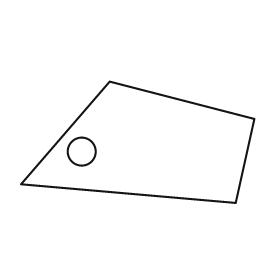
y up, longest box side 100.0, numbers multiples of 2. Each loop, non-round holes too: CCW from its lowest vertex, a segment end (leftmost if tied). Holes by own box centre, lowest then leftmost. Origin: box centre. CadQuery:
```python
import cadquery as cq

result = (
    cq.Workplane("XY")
    .moveTo(42.0, -26.0)
    .lineTo(50.0, 10.0)
    .lineTo(-12.0, 26.0)
    .lineTo(-50.0, -18.0)
    .close()
    .moveTo(-24.0, -4.0)
    .circle(6.0)
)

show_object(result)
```